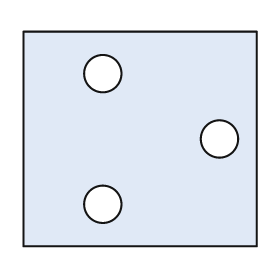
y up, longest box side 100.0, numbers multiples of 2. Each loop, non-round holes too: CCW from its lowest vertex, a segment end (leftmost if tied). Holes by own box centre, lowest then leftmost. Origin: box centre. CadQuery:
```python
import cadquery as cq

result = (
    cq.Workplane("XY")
    .moveTo(-50.0, -46.0)
    .lineTo(50.0, -46.0)
    .lineTo(50.0, 46.0)
    .lineTo(-50.0, 46.0)
    .close()
    .moveTo(-16.0, -28.0)
    .circle(8.0)
    .moveTo(34.0, 0.0)
    .circle(8.0)
    .moveTo(-16.0, 28.0)
    .circle(8.0)
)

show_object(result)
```